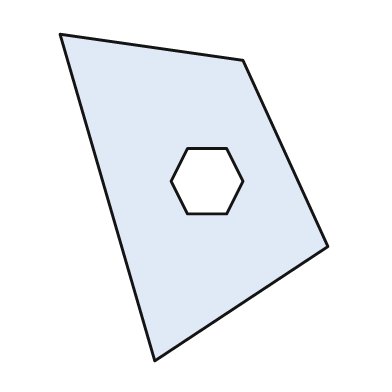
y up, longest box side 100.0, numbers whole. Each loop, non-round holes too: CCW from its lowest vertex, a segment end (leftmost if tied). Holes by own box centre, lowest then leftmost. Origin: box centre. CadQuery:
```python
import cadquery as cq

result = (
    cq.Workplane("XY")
    .moveTo(-12.0, -50.0)
    .lineTo(41.0, -15.0)
    .lineTo(15.0, 42.0)
    .lineTo(-41.0, 50.0)
    .close()
    .moveTo(-2.0, -5.0)
    .lineTo(10.0, -5.0)
    .lineTo(15.0, 5.0)
    .lineTo(10.0, 15.0)
    .lineTo(-2.0, 15.0)
    .lineTo(-7.0, 5.0)
    .close()
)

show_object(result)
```